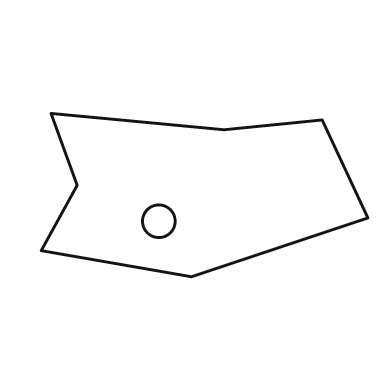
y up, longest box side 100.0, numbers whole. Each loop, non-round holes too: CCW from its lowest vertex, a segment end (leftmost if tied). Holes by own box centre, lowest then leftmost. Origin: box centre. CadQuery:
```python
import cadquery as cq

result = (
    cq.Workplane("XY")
    .moveTo(-4.0, -25.0)
    .lineTo(50.0, -7.0)
    .lineTo(36.0, 23.0)
    .lineTo(6.0, 20.0)
    .lineTo(-47.0, 25.0)
    .lineTo(-39.0, 3.0)
    .lineTo(-50.0, -17.0)
    .close()
    .moveTo(-14.0, -8.0)
    .circle(5.0)
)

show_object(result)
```